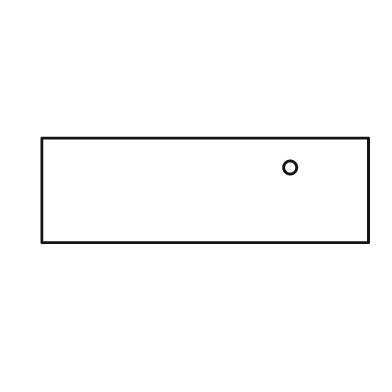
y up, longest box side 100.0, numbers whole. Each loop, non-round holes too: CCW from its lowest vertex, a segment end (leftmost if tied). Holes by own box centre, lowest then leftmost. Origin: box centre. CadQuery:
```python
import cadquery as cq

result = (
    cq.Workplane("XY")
    .moveTo(-50.0, -16.0)
    .lineTo(50.0, -16.0)
    .lineTo(50.0, 16.0)
    .lineTo(-50.0, 16.0)
    .close()
    .moveTo(26.0, 7.0)
    .circle(2.0)
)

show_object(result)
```